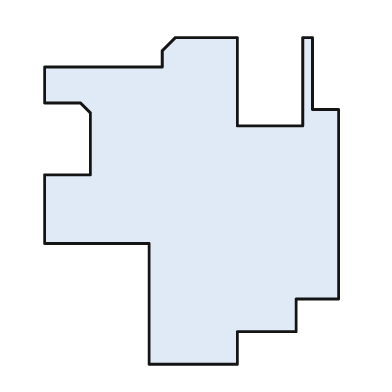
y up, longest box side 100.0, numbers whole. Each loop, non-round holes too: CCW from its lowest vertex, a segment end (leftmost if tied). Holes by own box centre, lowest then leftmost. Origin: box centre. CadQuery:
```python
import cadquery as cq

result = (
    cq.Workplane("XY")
    .moveTo(-13.0, -50.0)
    .lineTo(14.0, -50.0)
    .lineTo(14.0, -40.0)
    .lineTo(32.0, -40.0)
    .lineTo(32.0, -30.0)
    .lineTo(45.0, -30.0)
    .lineTo(45.0, 28.0)
    .lineTo(37.0, 28.0)
    .lineTo(37.0, 50.0)
    .lineTo(34.0, 50.0)
    .lineTo(34.0, 23.0)
    .lineTo(14.0, 23.0)
    .lineTo(14.0, 50.0)
    .lineTo(-5.0, 50.0)
    .lineTo(-9.0, 46.0)
    .lineTo(-9.0, 41.0)
    .lineTo(-45.0, 41.0)
    .lineTo(-45.0, 30.0)
    .lineTo(-34.0, 30.0)
    .lineTo(-31.0, 27.0)
    .lineTo(-31.0, 8.0)
    .lineTo(-45.0, 8.0)
    .lineTo(-45.0, -13.0)
    .lineTo(-13.0, -13.0)
    .close()
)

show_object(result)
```